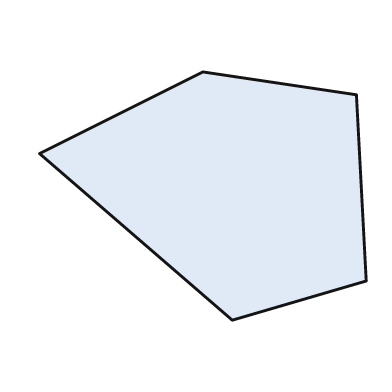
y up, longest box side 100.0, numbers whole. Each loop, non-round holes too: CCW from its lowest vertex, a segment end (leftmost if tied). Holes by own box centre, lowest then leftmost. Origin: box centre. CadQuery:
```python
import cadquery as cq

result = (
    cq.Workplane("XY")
    .moveTo(9.0, -38.0)
    .lineTo(50.0, -26.0)
    .lineTo(47.0, 31.0)
    .lineTo(0.0, 38.0)
    .lineTo(-50.0, 13.0)
    .close()
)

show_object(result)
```